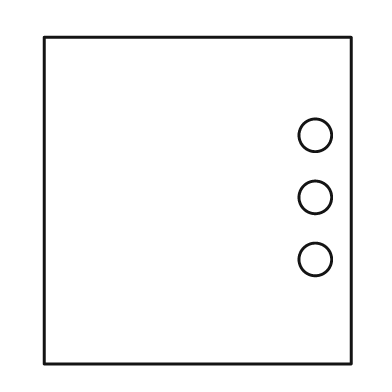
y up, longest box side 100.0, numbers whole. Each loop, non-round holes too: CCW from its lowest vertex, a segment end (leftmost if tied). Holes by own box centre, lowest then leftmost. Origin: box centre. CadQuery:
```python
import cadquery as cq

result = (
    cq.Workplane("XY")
    .moveTo(-47.0, -50.0)
    .lineTo(47.0, -50.0)
    .lineTo(47.0, 50.0)
    .lineTo(-47.0, 50.0)
    .close()
    .moveTo(36.0, -18.0)
    .circle(5.0)
    .moveTo(36.0, 1.0)
    .circle(5.0)
    .moveTo(36.0, 20.0)
    .circle(5.0)
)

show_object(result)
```